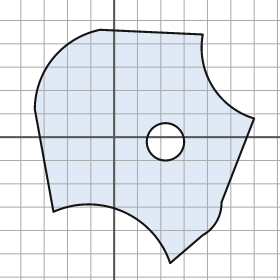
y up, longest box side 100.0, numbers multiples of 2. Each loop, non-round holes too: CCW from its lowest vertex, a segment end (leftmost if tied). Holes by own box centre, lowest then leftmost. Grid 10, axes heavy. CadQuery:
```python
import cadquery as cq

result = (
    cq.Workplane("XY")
    .moveTo(24.0, -54.0)
    .lineTo(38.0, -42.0)
    .threePointArc((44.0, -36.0), (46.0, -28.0))
    .lineTo(60.0, 8.0)
    .threePointArc((42.0, 22.0), (38.0, 44.0))
    .lineTo(-6.0, 46.0)
    .threePointArc((-26.0, 34.0), (-34.0, 12.0))
    .lineTo(-26.0, -32.0)
    .threePointArc((4.0, -32.0), (24.0, -54.0))
    .close()
    .moveTo(22.0, -2.0)
    .circle(8.0)
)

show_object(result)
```